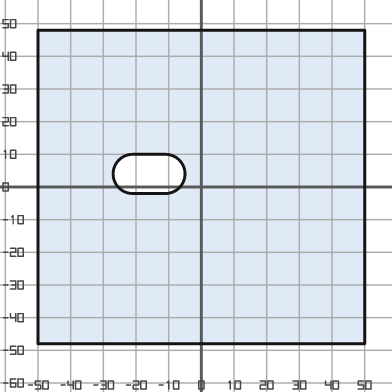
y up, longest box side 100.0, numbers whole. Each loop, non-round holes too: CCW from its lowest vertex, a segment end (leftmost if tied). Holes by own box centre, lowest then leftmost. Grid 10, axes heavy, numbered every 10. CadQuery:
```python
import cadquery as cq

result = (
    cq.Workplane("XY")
    .moveTo(-50.0, -48.0)
    .lineTo(50.0, -48.0)
    .lineTo(50.0, 48.0)
    .lineTo(-50.0, 48.0)
    .close()
    .moveTo(-21.0, -2.0)
    .lineTo(-11.0, -2.0)
    .threePointArc((-5.0, 4.0), (-11.0, 10.0))
    .lineTo(-21.0, 10.0)
    .threePointArc((-27.0, 4.0), (-21.0, -2.0))
    .close()
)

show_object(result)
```